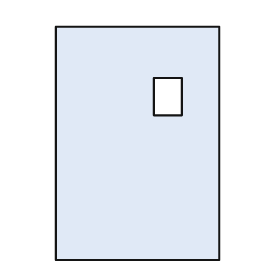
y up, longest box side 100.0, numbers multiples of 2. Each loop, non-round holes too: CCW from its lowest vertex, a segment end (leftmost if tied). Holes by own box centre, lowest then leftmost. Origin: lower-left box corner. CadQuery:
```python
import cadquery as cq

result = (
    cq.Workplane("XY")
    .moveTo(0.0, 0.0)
    .lineTo(70.0, 0.0)
    .lineTo(70.0, 100.0)
    .lineTo(0.0, 100.0)
    .close()
    .moveTo(42.0, 62.0)
    .lineTo(54.0, 62.0)
    .lineTo(54.0, 78.0)
    .lineTo(42.0, 78.0)
    .close()
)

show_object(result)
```